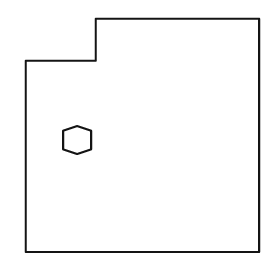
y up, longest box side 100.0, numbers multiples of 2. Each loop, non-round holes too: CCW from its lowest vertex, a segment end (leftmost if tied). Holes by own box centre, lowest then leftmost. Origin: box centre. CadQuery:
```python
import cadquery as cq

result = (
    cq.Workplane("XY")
    .moveTo(-50.0, -50.0)
    .lineTo(50.0, -50.0)
    .lineTo(50.0, 50.0)
    .lineTo(-20.0, 50.0)
    .lineTo(-20.0, 32.0)
    .lineTo(-50.0, 32.0)
    .close()
    .moveTo(-28.0, -8.0)
    .lineTo(-22.0, -6.0)
    .lineTo(-22.0, 2.0)
    .lineTo(-28.0, 4.0)
    .lineTo(-34.0, 2.0)
    .lineTo(-34.0, -6.0)
    .close()
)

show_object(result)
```